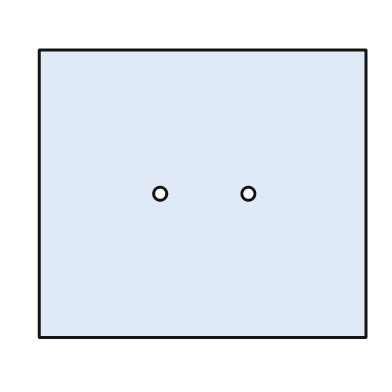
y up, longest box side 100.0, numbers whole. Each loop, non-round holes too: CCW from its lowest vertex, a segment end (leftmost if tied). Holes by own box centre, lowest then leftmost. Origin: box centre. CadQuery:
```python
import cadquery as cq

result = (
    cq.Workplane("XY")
    .moveTo(-50.0, -44.0)
    .lineTo(50.0, -44.0)
    .lineTo(50.0, 44.0)
    .lineTo(-50.0, 44.0)
    .close()
    .moveTo(-13.0, 0.0)
    .circle(2.0)
    .moveTo(14.0, 0.0)
    .circle(2.0)
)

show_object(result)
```